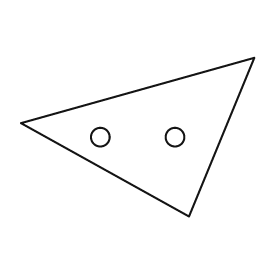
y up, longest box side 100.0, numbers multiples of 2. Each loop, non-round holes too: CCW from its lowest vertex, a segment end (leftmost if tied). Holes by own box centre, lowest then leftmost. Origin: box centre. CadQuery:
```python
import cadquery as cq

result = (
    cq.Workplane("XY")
    .moveTo(22.0, -34.0)
    .lineTo(50.0, 34.0)
    .lineTo(-50.0, 6.0)
    .close()
    .moveTo(-16.0, 0.0)
    .circle(4.0)
    .moveTo(16.0, 0.0)
    .circle(4.0)
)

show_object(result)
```